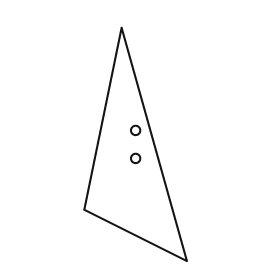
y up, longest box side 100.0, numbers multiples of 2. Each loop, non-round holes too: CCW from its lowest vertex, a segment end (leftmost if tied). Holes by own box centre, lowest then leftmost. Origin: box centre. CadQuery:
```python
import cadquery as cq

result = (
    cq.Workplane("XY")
    .moveTo(22.0, -50.0)
    .lineTo(-6.0, 50.0)
    .lineTo(-22.0, -28.0)
    .close()
    .moveTo(0.0, -6.0)
    .circle(2.0)
    .moveTo(0.0, 6.0)
    .circle(2.0)
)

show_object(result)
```